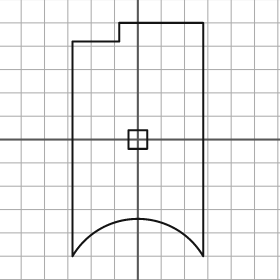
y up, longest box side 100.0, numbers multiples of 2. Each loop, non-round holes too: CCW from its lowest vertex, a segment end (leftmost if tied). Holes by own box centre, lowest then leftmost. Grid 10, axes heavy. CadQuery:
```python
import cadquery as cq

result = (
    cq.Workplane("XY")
    .moveTo(-28.0, -50.0)
    .threePointArc((0.0, -34.0), (28.0, -50.0))
    .lineTo(28.0, 50.0)
    .lineTo(-8.0, 50.0)
    .lineTo(-8.0, 42.0)
    .lineTo(-28.0, 42.0)
    .close()
    .moveTo(-4.0, -4.0)
    .lineTo(4.0, -4.0)
    .lineTo(4.0, 4.0)
    .lineTo(-4.0, 4.0)
    .close()
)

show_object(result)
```